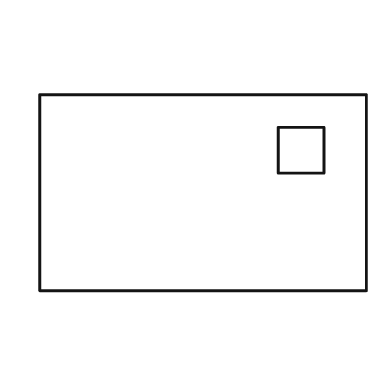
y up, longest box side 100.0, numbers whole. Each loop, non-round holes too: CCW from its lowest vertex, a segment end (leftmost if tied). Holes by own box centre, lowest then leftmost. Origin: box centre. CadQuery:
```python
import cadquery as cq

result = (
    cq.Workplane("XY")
    .moveTo(-50.0, -30.0)
    .lineTo(50.0, -30.0)
    .lineTo(50.0, 30.0)
    .lineTo(-50.0, 30.0)
    .close()
    .moveTo(23.0, 6.0)
    .lineTo(37.0, 6.0)
    .lineTo(37.0, 20.0)
    .lineTo(23.0, 20.0)
    .close()
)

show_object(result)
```